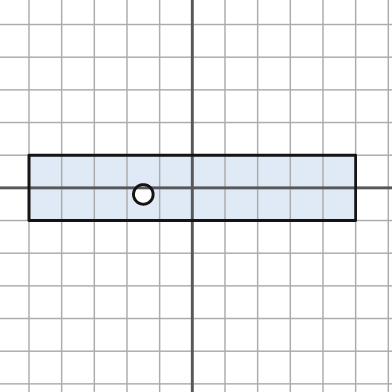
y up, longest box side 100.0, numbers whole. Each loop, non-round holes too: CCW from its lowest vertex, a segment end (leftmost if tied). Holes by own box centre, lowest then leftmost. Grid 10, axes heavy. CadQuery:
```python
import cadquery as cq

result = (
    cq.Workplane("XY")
    .moveTo(-50.0, -10.0)
    .lineTo(50.0, -10.0)
    .lineTo(50.0, 10.0)
    .lineTo(-50.0, 10.0)
    .close()
    .moveTo(-15.0, -2.0)
    .circle(3.0)
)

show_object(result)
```